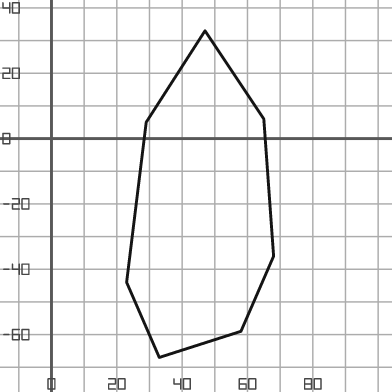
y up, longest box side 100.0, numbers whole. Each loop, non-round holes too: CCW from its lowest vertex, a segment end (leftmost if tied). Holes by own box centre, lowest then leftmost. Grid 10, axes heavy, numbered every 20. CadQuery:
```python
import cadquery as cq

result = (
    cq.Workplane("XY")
    .moveTo(33.0, -67.0)
    .lineTo(58.0, -59.0)
    .lineTo(68.0, -36.0)
    .lineTo(65.0, 6.0)
    .lineTo(47.0, 33.0)
    .lineTo(29.0, 5.0)
    .lineTo(23.0, -44.0)
    .close()
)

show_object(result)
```